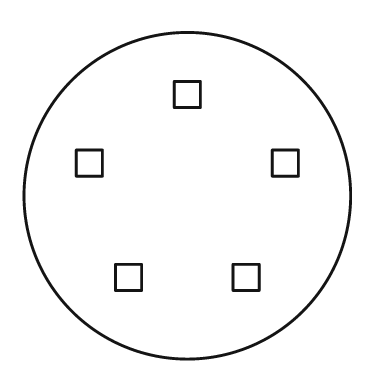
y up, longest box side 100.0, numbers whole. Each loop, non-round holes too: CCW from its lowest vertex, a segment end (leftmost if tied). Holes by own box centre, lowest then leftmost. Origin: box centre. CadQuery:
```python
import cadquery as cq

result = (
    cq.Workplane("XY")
    .moveTo(0.0, 0.0)
    .circle(50.0)
    .moveTo(-22.0, -29.0)
    .lineTo(-14.0, -29.0)
    .lineTo(-14.0, -21.0)
    .lineTo(-22.0, -21.0)
    .close()
    .moveTo(14.0, -29.0)
    .lineTo(22.0, -29.0)
    .lineTo(22.0, -21.0)
    .lineTo(14.0, -21.0)
    .close()
    .moveTo(-34.0, 6.0)
    .lineTo(-26.0, 6.0)
    .lineTo(-26.0, 14.0)
    .lineTo(-34.0, 14.0)
    .close()
    .moveTo(26.0, 6.0)
    .lineTo(34.0, 6.0)
    .lineTo(34.0, 14.0)
    .lineTo(26.0, 14.0)
    .close()
    .moveTo(-4.0, 27.0)
    .lineTo(4.0, 27.0)
    .lineTo(4.0, 35.0)
    .lineTo(-4.0, 35.0)
    .close()
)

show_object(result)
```